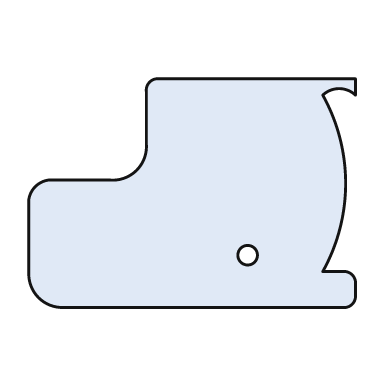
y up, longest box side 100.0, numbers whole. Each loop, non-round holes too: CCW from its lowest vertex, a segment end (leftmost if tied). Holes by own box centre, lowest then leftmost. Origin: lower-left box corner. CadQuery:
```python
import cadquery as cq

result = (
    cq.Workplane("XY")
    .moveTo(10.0, 0.0)
    .lineTo(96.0, 0.0)
    .threePointArc((99.0, 1.0), (100.0, 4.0))
    .lineTo(100.0, 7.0)
    .threePointArc((99.0, 10.0), (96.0, 11.0))
    .lineTo(90.0, 11.0)
    .threePointArc((97.0, 38.0), (90.0, 65.0))
    .threePointArc((95.0, 67.0), (100.0, 65.0))
    .lineTo(100.0, 70.0)
    .lineTo(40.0, 70.0)
    .threePointArc((37.0, 69.0), (36.0, 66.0))
    .lineTo(36.0, 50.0)
    .threePointArc((33.0, 42.0), (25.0, 39.0))
    .lineTo(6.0, 39.0)
    .threePointArc((2.0, 37.0), (0.0, 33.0))
    .lineTo(0.0, 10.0)
    .threePointArc((3.0, 3.0), (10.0, 0.0))
    .close()
    .moveTo(67.0, 16.0)
    .circle(3.0)
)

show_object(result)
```